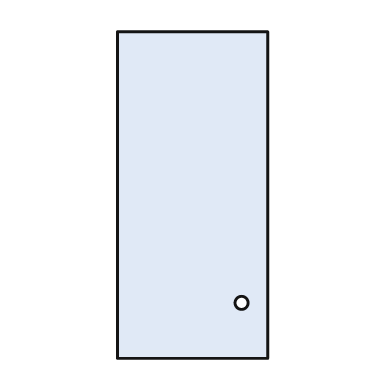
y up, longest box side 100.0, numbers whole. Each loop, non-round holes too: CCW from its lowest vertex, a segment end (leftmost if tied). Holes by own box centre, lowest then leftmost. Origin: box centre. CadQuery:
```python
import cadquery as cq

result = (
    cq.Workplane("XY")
    .moveTo(-23.0, -50.0)
    .lineTo(23.0, -50.0)
    .lineTo(23.0, 50.0)
    .lineTo(-23.0, 50.0)
    .close()
    .moveTo(15.0, -33.0)
    .circle(2.0)
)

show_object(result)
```